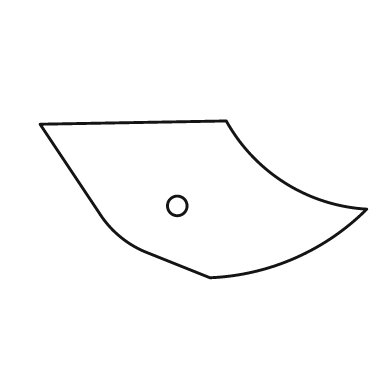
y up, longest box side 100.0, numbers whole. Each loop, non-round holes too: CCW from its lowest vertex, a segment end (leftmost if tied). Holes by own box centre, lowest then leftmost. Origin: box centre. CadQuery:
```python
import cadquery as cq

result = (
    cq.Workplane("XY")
    .moveTo(2.0, -24.0)
    .threePointArc((28.0, -18.0), (50.0, -3.0))
    .threePointArc((25.0, 5.0), (7.0, 24.0))
    .lineTo(-50.0, 23.0)
    .lineTo(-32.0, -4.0)
    .threePointArc((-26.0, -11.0), (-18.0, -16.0))
    .close()
    .moveTo(-8.0, -2.0)
    .circle(3.0)
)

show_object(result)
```